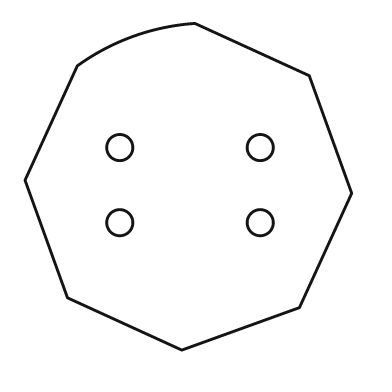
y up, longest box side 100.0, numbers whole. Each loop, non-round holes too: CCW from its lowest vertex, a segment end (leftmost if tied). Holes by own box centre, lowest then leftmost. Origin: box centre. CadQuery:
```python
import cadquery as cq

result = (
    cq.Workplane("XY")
    .moveTo(-2.0, -50.0)
    .lineTo(34.0, -37.0)
    .lineTo(50.0, -2.0)
    .lineTo(37.0, 34.0)
    .lineTo(2.0, 50.0)
    .threePointArc((-17.0, 46.0), (-34.0, 37.0))
    .lineTo(-50.0, 2.0)
    .lineTo(-37.0, -34.0)
    .close()
    .moveTo(-21.0, -11.0)
    .circle(4.0)
    .moveTo(22.0, -11.0)
    .circle(4.0)
    .moveTo(-21.0, 12.0)
    .circle(4.0)
    .moveTo(22.0, 12.0)
    .circle(4.0)
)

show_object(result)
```